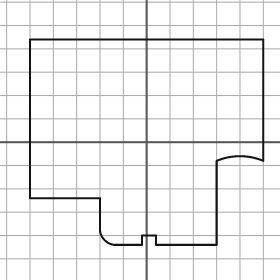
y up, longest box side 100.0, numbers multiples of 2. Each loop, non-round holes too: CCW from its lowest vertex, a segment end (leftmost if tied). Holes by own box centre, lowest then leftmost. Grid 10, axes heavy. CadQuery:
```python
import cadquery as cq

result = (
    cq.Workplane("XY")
    .moveTo(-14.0, -44.0)
    .lineTo(-2.0, -44.0)
    .lineTo(-2.0, -40.0)
    .lineTo(4.0, -40.0)
    .lineTo(4.0, -44.0)
    .lineTo(30.0, -44.0)
    .lineTo(30.0, -8.0)
    .threePointArc((40.0, -6.0), (50.0, -8.0))
    .lineTo(50.0, 44.0)
    .lineTo(-50.0, 44.0)
    .lineTo(-50.0, -24.0)
    .lineTo(-20.0, -24.0)
    .lineTo(-20.0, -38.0)
    .threePointArc((-18.0, -42.0), (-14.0, -44.0))
    .close()
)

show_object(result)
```